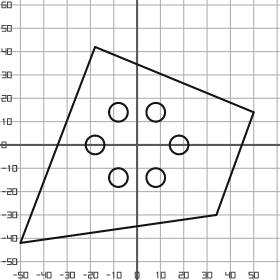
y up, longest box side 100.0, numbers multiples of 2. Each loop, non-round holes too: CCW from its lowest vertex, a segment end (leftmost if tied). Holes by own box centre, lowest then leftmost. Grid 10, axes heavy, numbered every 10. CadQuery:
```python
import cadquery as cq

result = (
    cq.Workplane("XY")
    .moveTo(-50.0, -42.0)
    .lineTo(34.0, -30.0)
    .lineTo(50.0, 14.0)
    .lineTo(-18.0, 42.0)
    .close()
    .moveTo(-8.0, -14.0)
    .circle(4.0)
    .moveTo(8.0, -14.0)
    .circle(4.0)
    .moveTo(-18.0, 0.0)
    .circle(4.0)
    .moveTo(18.0, 0.0)
    .circle(4.0)
    .moveTo(-8.0, 14.0)
    .circle(4.0)
    .moveTo(8.0, 14.0)
    .circle(4.0)
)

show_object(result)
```